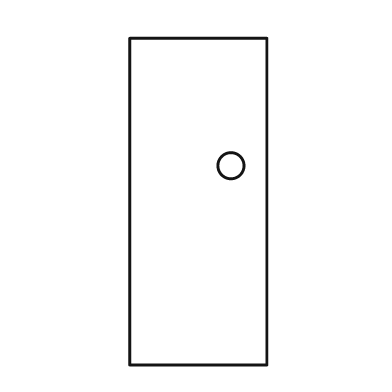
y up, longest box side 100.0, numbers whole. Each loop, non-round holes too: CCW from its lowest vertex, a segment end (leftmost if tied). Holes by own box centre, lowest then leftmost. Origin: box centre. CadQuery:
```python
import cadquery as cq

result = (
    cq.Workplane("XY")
    .moveTo(-21.0, -50.0)
    .lineTo(21.0, -50.0)
    .lineTo(21.0, 50.0)
    .lineTo(-21.0, 50.0)
    .close()
    .moveTo(10.0, 11.0)
    .circle(4.0)
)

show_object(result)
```